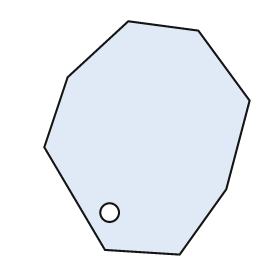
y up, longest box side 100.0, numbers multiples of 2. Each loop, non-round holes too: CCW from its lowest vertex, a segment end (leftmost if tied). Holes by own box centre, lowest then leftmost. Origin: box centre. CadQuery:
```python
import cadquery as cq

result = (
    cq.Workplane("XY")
    .moveTo(14.0, -50.0)
    .lineTo(34.0, -22.0)
    .lineTo(44.0, 16.0)
    .lineTo(22.0, 46.0)
    .lineTo(-8.0, 50.0)
    .lineTo(-34.0, 26.0)
    .lineTo(-44.0, -4.0)
    .lineTo(-18.0, -48.0)
    .close()
    .moveTo(-16.0, -32.0)
    .circle(4.0)
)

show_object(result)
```